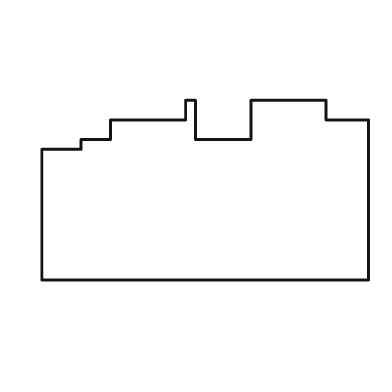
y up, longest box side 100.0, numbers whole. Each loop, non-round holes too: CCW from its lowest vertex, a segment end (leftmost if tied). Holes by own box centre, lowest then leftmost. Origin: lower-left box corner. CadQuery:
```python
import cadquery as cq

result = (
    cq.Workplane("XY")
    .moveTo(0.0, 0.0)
    .lineTo(100.0, 0.0)
    .lineTo(100.0, 49.0)
    .lineTo(87.0, 49.0)
    .lineTo(87.0, 55.0)
    .lineTo(64.0, 55.0)
    .lineTo(64.0, 43.0)
    .lineTo(47.0, 43.0)
    .lineTo(47.0, 55.0)
    .lineTo(44.0, 55.0)
    .lineTo(44.0, 49.0)
    .lineTo(21.0, 49.0)
    .lineTo(21.0, 43.0)
    .lineTo(12.0, 43.0)
    .lineTo(12.0, 40.0)
    .lineTo(0.0, 40.0)
    .close()
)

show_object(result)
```